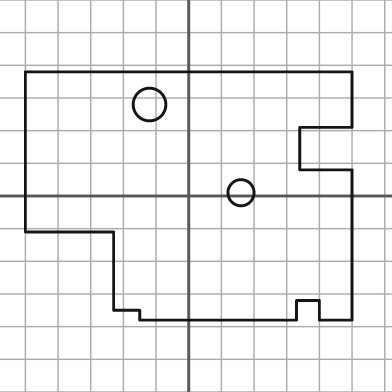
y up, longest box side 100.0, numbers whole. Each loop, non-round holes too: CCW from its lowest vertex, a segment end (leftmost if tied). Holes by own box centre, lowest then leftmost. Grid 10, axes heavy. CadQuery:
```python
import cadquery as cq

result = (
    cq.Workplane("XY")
    .moveTo(-15.0, -38.0)
    .lineTo(33.0, -38.0)
    .lineTo(33.0, -32.0)
    .lineTo(40.0, -32.0)
    .lineTo(40.0, -38.0)
    .lineTo(50.0, -38.0)
    .lineTo(50.0, 8.0)
    .lineTo(34.0, 8.0)
    .lineTo(34.0, 21.0)
    .lineTo(50.0, 21.0)
    .lineTo(50.0, 38.0)
    .lineTo(-50.0, 38.0)
    .lineTo(-50.0, -11.0)
    .lineTo(-23.0, -11.0)
    .lineTo(-23.0, -35.0)
    .lineTo(-15.0, -35.0)
    .close()
    .moveTo(16.0, 1.0)
    .circle(4.0)
    .moveTo(-12.0, 28.0)
    .circle(5.0)
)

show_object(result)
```